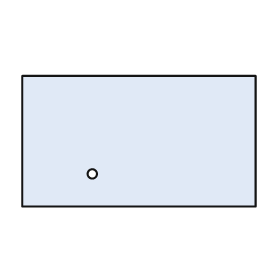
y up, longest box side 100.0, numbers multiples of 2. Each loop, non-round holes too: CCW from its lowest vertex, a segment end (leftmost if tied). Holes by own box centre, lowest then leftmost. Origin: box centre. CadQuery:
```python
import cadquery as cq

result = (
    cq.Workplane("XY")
    .moveTo(-50.0, -28.0)
    .lineTo(50.0, -28.0)
    .lineTo(50.0, 28.0)
    .lineTo(-50.0, 28.0)
    .close()
    .moveTo(-20.0, -14.0)
    .circle(2.0)
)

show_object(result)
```